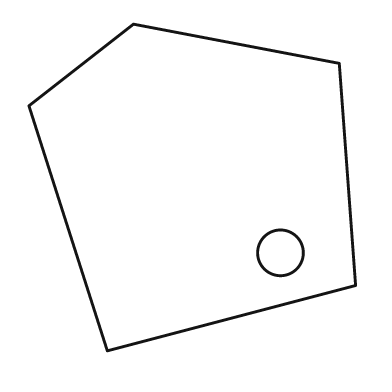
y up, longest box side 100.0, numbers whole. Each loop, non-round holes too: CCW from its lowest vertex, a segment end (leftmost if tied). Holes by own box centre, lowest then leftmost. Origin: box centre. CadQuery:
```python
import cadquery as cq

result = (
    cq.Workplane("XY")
    .moveTo(-26.0, -50.0)
    .lineTo(50.0, -30.0)
    .lineTo(45.0, 38.0)
    .lineTo(-18.0, 50.0)
    .lineTo(-50.0, 25.0)
    .close()
    .moveTo(27.0, -20.0)
    .circle(7.0)
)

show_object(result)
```